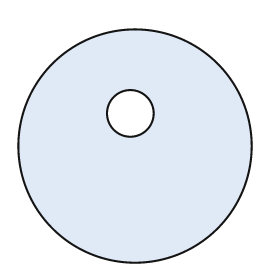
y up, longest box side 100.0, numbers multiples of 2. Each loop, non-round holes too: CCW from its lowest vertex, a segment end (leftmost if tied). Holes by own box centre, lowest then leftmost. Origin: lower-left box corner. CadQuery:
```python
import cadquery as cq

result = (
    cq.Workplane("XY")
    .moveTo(50.0, 50.0)
    .circle(50.0)
    .moveTo(48.0, 64.0)
    .circle(10.0)
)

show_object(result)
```